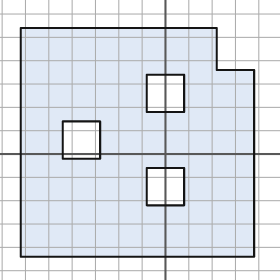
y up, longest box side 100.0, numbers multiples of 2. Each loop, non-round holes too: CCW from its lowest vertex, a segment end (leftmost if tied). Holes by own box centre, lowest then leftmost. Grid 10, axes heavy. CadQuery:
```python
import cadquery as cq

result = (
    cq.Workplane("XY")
    .moveTo(-62.0, -44.0)
    .lineTo(38.0, -44.0)
    .lineTo(38.0, 36.0)
    .lineTo(22.0, 36.0)
    .lineTo(22.0, 54.0)
    .lineTo(-62.0, 54.0)
    .close()
    .moveTo(-8.0, -22.0)
    .lineTo(8.0, -22.0)
    .lineTo(8.0, -6.0)
    .lineTo(-8.0, -6.0)
    .close()
    .moveTo(-44.0, -2.0)
    .lineTo(-28.0, -2.0)
    .lineTo(-28.0, 14.0)
    .lineTo(-44.0, 14.0)
    .close()
    .moveTo(-8.0, 18.0)
    .lineTo(8.0, 18.0)
    .lineTo(8.0, 34.0)
    .lineTo(-8.0, 34.0)
    .close()
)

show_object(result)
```